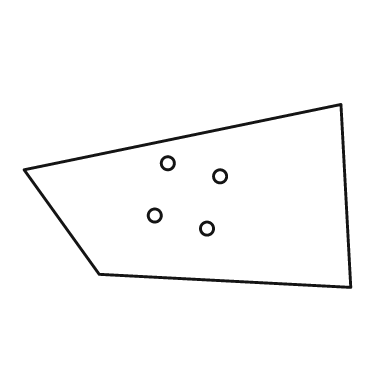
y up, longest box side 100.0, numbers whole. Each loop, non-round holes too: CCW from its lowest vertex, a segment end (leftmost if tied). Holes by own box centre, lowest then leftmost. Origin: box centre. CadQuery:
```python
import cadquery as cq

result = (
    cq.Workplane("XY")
    .moveTo(50.0, -28.0)
    .lineTo(47.0, 28.0)
    .lineTo(-50.0, 8.0)
    .lineTo(-27.0, -24.0)
    .close()
    .moveTo(6.0, -10.0)
    .circle(2.0)
    .moveTo(-10.0, -6.0)
    .circle(2.0)
    .moveTo(10.0, 6.0)
    .circle(2.0)
    .moveTo(-6.0, 10.0)
    .circle(2.0)
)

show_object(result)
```